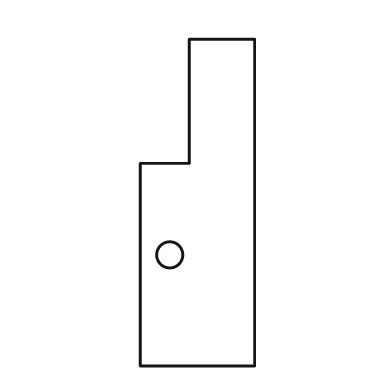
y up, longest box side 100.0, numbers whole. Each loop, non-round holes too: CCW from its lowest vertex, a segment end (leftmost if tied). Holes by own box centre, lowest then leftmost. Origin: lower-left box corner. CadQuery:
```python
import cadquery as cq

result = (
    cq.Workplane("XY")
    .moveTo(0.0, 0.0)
    .lineTo(35.0, 0.0)
    .lineTo(35.0, 100.0)
    .lineTo(15.0, 100.0)
    .lineTo(15.0, 62.0)
    .lineTo(0.0, 62.0)
    .close()
    .moveTo(9.0, 34.0)
    .circle(4.0)
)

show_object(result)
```